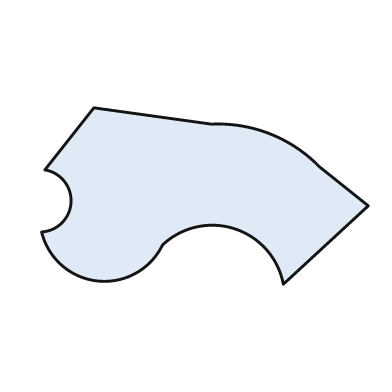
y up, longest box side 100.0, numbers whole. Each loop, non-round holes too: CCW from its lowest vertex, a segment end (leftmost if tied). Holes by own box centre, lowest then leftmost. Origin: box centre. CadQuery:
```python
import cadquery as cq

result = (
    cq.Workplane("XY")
    .moveTo(24.0, -27.0)
    .lineTo(50.0, -3.0)
    .lineTo(35.0, 9.0)
    .threePointArc((20.0, 19.0), (2.0, 22.0))
    .lineTo(-34.0, 27.0)
    .lineTo(-49.0, 8.0)
    .threePointArc((-41.0, -2.0), (-50.0, -11.0))
    .threePointArc((-33.0, -26.0), (-13.0, -15.0))
    .threePointArc((9.0, -10.0), (24.0, -27.0))
    .close()
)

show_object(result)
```